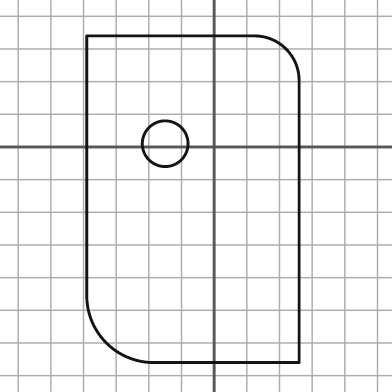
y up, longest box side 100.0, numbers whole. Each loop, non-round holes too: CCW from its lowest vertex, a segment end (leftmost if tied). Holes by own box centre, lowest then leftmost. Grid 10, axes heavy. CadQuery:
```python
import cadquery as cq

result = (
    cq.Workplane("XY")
    .moveTo(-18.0, -66.0)
    .lineTo(26.0, -66.0)
    .lineTo(26.0, 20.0)
    .threePointArc((22.0, 30.0), (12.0, 34.0))
    .lineTo(-39.0, 34.0)
    .lineTo(-39.0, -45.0)
    .threePointArc((-33.0, -60.0), (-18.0, -66.0))
    .close()
    .moveTo(-15.0, 1.0)
    .circle(7.0)
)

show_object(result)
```